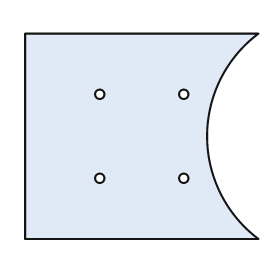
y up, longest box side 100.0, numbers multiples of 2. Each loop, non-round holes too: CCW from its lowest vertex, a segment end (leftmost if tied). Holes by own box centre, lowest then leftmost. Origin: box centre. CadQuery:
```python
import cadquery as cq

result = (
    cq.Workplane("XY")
    .moveTo(-50.0, -44.0)
    .lineTo(50.0, -44.0)
    .threePointArc((28.0, 0.0), (50.0, 44.0))
    .lineTo(-50.0, 44.0)
    .close()
    .moveTo(-18.0, -18.0)
    .circle(2.0)
    .moveTo(18.0, -18.0)
    .circle(2.0)
    .moveTo(-18.0, 18.0)
    .circle(2.0)
    .moveTo(18.0, 18.0)
    .circle(2.0)
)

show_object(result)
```